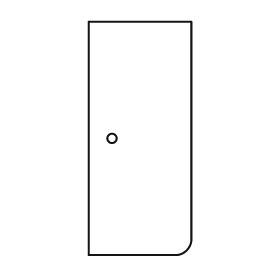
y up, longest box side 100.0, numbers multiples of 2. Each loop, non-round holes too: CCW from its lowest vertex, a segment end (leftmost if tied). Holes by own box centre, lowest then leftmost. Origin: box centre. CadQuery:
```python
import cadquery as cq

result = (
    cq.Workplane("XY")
    .moveTo(-22.0, -50.0)
    .lineTo(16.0, -50.0)
    .threePointArc((20.0, -48.0), (22.0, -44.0))
    .lineTo(22.0, 50.0)
    .lineTo(-22.0, 50.0)
    .close()
    .moveTo(-12.0, 0.0)
    .circle(2.0)
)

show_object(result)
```